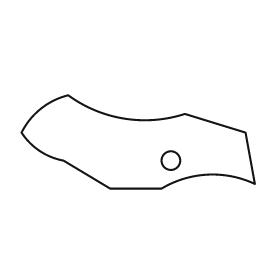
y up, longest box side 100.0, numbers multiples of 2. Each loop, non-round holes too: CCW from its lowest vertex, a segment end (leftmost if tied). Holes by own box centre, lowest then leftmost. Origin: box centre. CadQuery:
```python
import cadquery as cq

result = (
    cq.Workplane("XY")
    .moveTo(-12.0, -20.0)
    .lineTo(10.0, -20.0)
    .threePointArc((30.0, -14.0), (50.0, -18.0))
    .lineTo(46.0, 4.0)
    .lineTo(20.0, 12.0)
    .threePointArc((-6.0, 10.0), (-30.0, 20.0))
    .threePointArc((-42.0, 14.0), (-50.0, 4.0))
    .threePointArc((-42.0, -4.0), (-32.0, -8.0))
    .close()
    .moveTo(14.0, -8.0)
    .circle(4.0)
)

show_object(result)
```